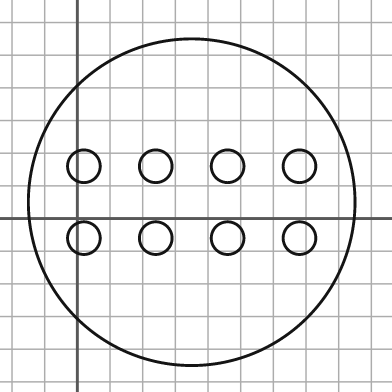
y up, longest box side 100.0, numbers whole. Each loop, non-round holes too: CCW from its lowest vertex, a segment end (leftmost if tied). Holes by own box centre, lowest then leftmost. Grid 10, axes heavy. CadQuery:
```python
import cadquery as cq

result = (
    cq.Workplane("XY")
    .moveTo(35.0, 5.0)
    .circle(50.0)
    .moveTo(2.0, -6.0)
    .circle(5.0)
    .moveTo(24.0, -6.0)
    .circle(5.0)
    .moveTo(46.0, -6.0)
    .circle(5.0)
    .moveTo(68.0, -6.0)
    .circle(5.0)
    .moveTo(2.0, 16.0)
    .circle(5.0)
    .moveTo(24.0, 16.0)
    .circle(5.0)
    .moveTo(46.0, 16.0)
    .circle(5.0)
    .moveTo(68.0, 16.0)
    .circle(5.0)
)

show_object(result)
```